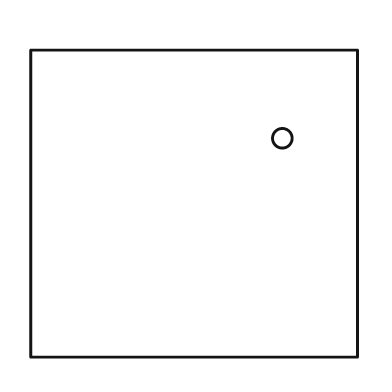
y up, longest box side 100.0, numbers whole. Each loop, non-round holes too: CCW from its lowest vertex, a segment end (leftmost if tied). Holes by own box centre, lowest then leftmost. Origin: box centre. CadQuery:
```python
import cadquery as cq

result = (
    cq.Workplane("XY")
    .moveTo(-50.0, -47.0)
    .lineTo(50.0, -47.0)
    .lineTo(50.0, 47.0)
    .lineTo(-50.0, 47.0)
    .close()
    .moveTo(27.0, 20.0)
    .circle(3.0)
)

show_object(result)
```